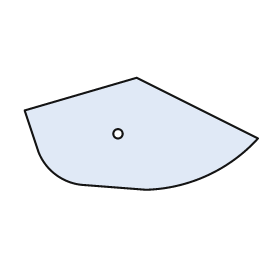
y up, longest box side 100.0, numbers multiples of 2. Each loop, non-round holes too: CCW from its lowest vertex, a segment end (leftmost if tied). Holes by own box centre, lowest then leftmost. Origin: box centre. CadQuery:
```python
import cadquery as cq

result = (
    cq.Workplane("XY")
    .moveTo(2.0, -24.0)
    .threePointArc((28.0, -18.0), (50.0, -2.0))
    .lineTo(-2.0, 24.0)
    .lineTo(-50.0, 10.0)
    .lineTo(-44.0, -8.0)
    .threePointArc((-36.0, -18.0), (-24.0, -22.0))
    .close()
    .moveTo(-10.0, 0.0)
    .circle(2.0)
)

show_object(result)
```